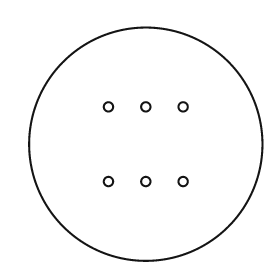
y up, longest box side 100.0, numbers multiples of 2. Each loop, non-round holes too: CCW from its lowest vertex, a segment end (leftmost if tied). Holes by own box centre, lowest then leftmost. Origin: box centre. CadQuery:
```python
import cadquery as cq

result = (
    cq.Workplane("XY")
    .moveTo(0.0, 0.0)
    .circle(50.0)
    .moveTo(-16.0, -16.0)
    .circle(2.0)
    .moveTo(0.0, -16.0)
    .circle(2.0)
    .moveTo(16.0, -16.0)
    .circle(2.0)
    .moveTo(-16.0, 16.0)
    .circle(2.0)
    .moveTo(0.0, 16.0)
    .circle(2.0)
    .moveTo(16.0, 16.0)
    .circle(2.0)
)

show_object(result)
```